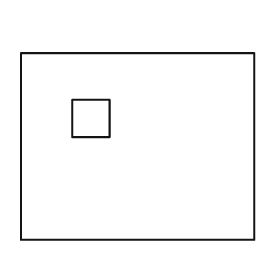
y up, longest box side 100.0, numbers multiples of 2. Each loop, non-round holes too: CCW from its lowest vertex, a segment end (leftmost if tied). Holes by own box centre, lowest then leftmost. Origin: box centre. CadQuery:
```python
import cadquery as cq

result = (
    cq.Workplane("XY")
    .moveTo(-50.0, -40.0)
    .lineTo(50.0, -40.0)
    .lineTo(50.0, 40.0)
    .lineTo(-50.0, 40.0)
    .close()
    .moveTo(-28.0, 4.0)
    .lineTo(-12.0, 4.0)
    .lineTo(-12.0, 20.0)
    .lineTo(-28.0, 20.0)
    .close()
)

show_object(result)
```